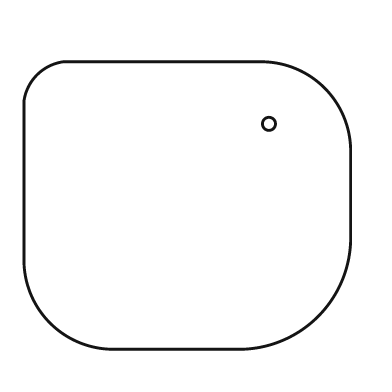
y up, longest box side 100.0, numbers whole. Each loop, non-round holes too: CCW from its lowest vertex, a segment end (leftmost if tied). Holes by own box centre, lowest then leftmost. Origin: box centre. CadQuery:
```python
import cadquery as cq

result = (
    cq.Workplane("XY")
    .moveTo(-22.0, -44.0)
    .lineTo(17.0, -44.0)
    .threePointArc((40.0, -34.0), (50.0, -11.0))
    .lineTo(50.0, 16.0)
    .threePointArc((42.0, 36.0), (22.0, 44.0))
    .lineTo(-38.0, 44.0)
    .threePointArc((-46.0, 40.0), (-50.0, 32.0))
    .lineTo(-50.0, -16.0)
    .threePointArc((-42.0, -36.0), (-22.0, -44.0))
    .close()
    .moveTo(25.0, 25.0)
    .circle(2.0)
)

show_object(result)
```